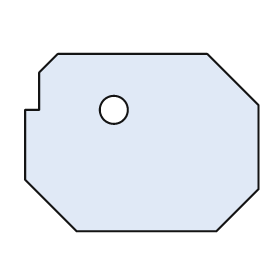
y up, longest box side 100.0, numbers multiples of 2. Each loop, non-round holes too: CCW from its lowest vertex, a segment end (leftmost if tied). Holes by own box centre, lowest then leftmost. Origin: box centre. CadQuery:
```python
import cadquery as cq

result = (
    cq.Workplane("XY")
    .moveTo(-28.0, -38.0)
    .lineTo(32.0, -38.0)
    .lineTo(50.0, -20.0)
    .lineTo(50.0, 16.0)
    .lineTo(28.0, 38.0)
    .lineTo(-36.0, 38.0)
    .lineTo(-44.0, 30.0)
    .lineTo(-44.0, 14.0)
    .lineTo(-50.0, 14.0)
    .lineTo(-50.0, -16.0)
    .close()
    .moveTo(-12.0, 14.0)
    .circle(6.0)
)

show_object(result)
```